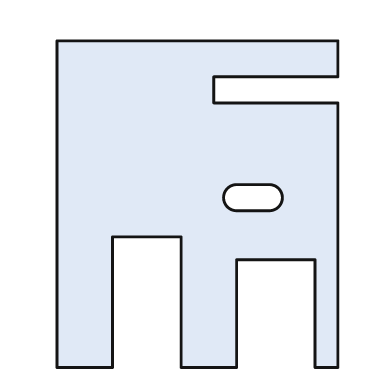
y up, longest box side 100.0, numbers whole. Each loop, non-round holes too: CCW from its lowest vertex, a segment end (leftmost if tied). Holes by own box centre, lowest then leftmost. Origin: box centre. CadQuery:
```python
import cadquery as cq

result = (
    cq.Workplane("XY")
    .moveTo(-43.0, -50.0)
    .lineTo(-26.0, -50.0)
    .lineTo(-26.0, -10.0)
    .lineTo(-5.0, -10.0)
    .lineTo(-5.0, -50.0)
    .lineTo(12.0, -50.0)
    .lineTo(12.0, -17.0)
    .lineTo(36.0, -17.0)
    .lineTo(36.0, -50.0)
    .lineTo(43.0, -50.0)
    .lineTo(43.0, 31.0)
    .lineTo(5.0, 31.0)
    .lineTo(5.0, 39.0)
    .lineTo(43.0, 39.0)
    .lineTo(43.0, 50.0)
    .lineTo(-43.0, 50.0)
    .close()
    .moveTo(12.0, -2.0)
    .lineTo(22.0, -2.0)
    .threePointArc((26.0, 2.0), (22.0, 6.0))
    .lineTo(12.0, 6.0)
    .threePointArc((8.0, 2.0), (12.0, -2.0))
    .close()
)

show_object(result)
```